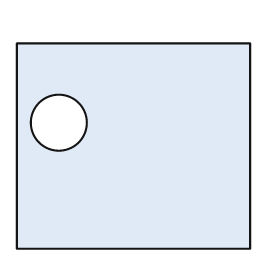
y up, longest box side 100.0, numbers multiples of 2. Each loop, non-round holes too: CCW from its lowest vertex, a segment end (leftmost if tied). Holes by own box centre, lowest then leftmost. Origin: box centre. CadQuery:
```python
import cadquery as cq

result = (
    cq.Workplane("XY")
    .moveTo(-50.0, -44.0)
    .lineTo(50.0, -44.0)
    .lineTo(50.0, 44.0)
    .lineTo(-50.0, 44.0)
    .close()
    .moveTo(-32.0, 10.0)
    .circle(12.0)
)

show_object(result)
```